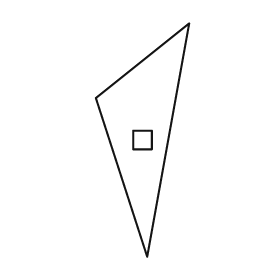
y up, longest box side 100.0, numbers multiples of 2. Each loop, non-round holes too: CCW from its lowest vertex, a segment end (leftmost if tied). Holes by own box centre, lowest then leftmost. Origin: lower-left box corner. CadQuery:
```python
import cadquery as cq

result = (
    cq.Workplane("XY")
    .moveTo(22.0, 0.0)
    .lineTo(40.0, 100.0)
    .lineTo(0.0, 68.0)
    .close()
    .moveTo(16.0, 46.0)
    .lineTo(24.0, 46.0)
    .lineTo(24.0, 54.0)
    .lineTo(16.0, 54.0)
    .close()
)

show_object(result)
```